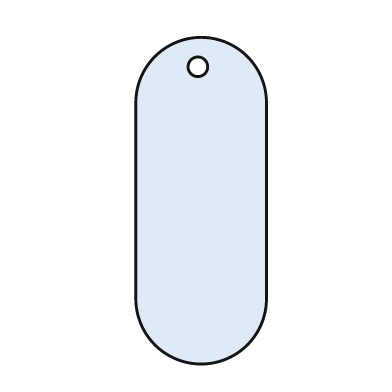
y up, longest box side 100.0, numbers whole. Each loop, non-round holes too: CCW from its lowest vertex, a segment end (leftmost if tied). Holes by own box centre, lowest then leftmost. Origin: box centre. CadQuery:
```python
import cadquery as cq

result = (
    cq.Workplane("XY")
    .moveTo(-20.0, -30.0)
    .threePointArc((0.0, -50.0), (20.0, -30.0))
    .lineTo(20.0, 30.0)
    .threePointArc((0.0, 50.0), (-20.0, 30.0))
    .close()
    .moveTo(-1.0, 41.0)
    .circle(3.0)
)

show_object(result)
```